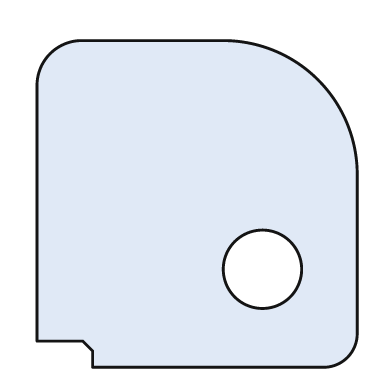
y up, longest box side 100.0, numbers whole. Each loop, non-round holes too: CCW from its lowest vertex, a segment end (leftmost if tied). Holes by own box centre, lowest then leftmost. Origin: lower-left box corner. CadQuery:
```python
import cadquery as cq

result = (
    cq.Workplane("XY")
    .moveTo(17.0, 0.0)
    .lineTo(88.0, 0.0)
    .threePointArc((95.0, 3.0), (98.0, 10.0))
    .lineTo(98.0, 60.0)
    .threePointArc((86.0, 88.0), (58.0, 100.0))
    .lineTo(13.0, 100.0)
    .threePointArc((4.0, 96.0), (0.0, 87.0))
    .lineTo(0.0, 8.0)
    .lineTo(14.0, 8.0)
    .lineTo(17.0, 5.0)
    .close()
    .moveTo(69.0, 30.0)
    .circle(12.0)
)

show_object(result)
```